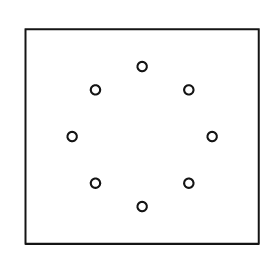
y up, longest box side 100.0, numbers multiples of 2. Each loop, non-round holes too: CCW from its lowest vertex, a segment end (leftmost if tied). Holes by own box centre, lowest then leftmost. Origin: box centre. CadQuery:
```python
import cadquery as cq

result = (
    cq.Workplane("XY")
    .moveTo(-50.0, -46.0)
    .lineTo(50.0, -46.0)
    .lineTo(50.0, 46.0)
    .lineTo(-50.0, 46.0)
    .close()
    .moveTo(0.0, -30.0)
    .circle(2.0)
    .moveTo(-20.0, -20.0)
    .circle(2.0)
    .moveTo(20.0, -20.0)
    .circle(2.0)
    .moveTo(-30.0, 0.0)
    .circle(2.0)
    .moveTo(30.0, 0.0)
    .circle(2.0)
    .moveTo(-20.0, 20.0)
    .circle(2.0)
    .moveTo(20.0, 20.0)
    .circle(2.0)
    .moveTo(0.0, 30.0)
    .circle(2.0)
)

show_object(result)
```